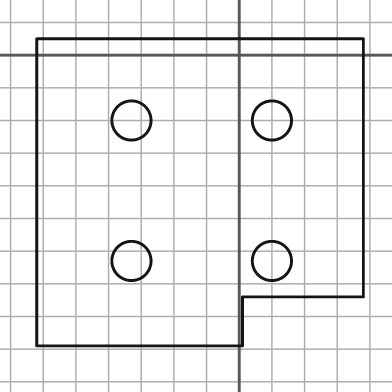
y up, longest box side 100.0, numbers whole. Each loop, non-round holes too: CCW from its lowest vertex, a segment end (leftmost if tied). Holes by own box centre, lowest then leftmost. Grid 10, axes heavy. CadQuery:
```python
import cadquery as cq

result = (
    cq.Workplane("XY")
    .moveTo(-62.0, -89.0)
    .lineTo(1.0, -89.0)
    .lineTo(1.0, -74.0)
    .lineTo(38.0, -74.0)
    .lineTo(38.0, 5.0)
    .lineTo(-62.0, 5.0)
    .close()
    .moveTo(-33.0, -63.0)
    .circle(6.0)
    .moveTo(10.0, -63.0)
    .circle(6.0)
    .moveTo(-33.0, -20.0)
    .circle(6.0)
    .moveTo(10.0, -20.0)
    .circle(6.0)
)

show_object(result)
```